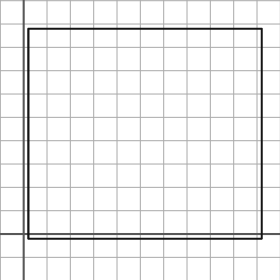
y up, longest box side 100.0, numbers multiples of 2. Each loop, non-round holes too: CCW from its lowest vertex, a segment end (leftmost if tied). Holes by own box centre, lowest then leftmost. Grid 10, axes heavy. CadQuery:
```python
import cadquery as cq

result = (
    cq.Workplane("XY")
    .moveTo(2.0, -2.0)
    .lineTo(102.0, -2.0)
    .lineTo(102.0, 88.0)
    .lineTo(2.0, 88.0)
    .close()
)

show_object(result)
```